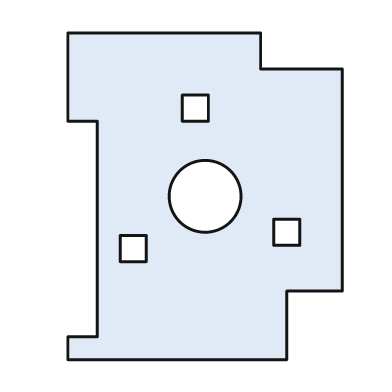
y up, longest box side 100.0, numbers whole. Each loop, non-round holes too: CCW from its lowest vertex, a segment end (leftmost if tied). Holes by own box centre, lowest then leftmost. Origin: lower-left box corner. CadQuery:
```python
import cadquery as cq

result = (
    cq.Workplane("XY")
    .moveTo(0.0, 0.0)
    .lineTo(67.0, 0.0)
    .lineTo(67.0, 21.0)
    .lineTo(84.0, 21.0)
    .lineTo(84.0, 89.0)
    .lineTo(59.0, 89.0)
    .lineTo(59.0, 100.0)
    .lineTo(0.0, 100.0)
    .lineTo(0.0, 73.0)
    .lineTo(9.0, 73.0)
    .lineTo(9.0, 7.0)
    .lineTo(0.0, 7.0)
    .close()
    .moveTo(16.0, 30.0)
    .lineTo(24.0, 30.0)
    .lineTo(24.0, 38.0)
    .lineTo(16.0, 38.0)
    .close()
    .moveTo(63.0, 35.0)
    .lineTo(71.0, 35.0)
    .lineTo(71.0, 43.0)
    .lineTo(63.0, 43.0)
    .close()
    .moveTo(42.0, 50.0)
    .circle(11.0)
    .moveTo(35.0, 73.0)
    .lineTo(43.0, 73.0)
    .lineTo(43.0, 81.0)
    .lineTo(35.0, 81.0)
    .close()
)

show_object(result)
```